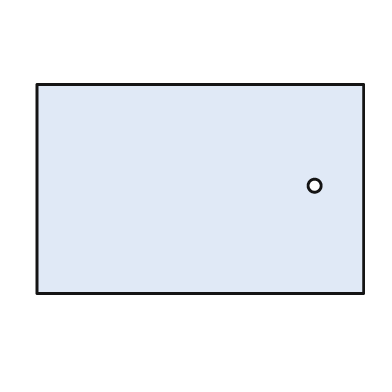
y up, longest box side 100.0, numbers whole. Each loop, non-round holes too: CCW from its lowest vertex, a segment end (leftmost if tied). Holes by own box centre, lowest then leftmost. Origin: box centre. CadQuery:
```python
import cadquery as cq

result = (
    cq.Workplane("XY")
    .moveTo(-50.0, -32.0)
    .lineTo(50.0, -32.0)
    .lineTo(50.0, 32.0)
    .lineTo(-50.0, 32.0)
    .close()
    .moveTo(35.0, 1.0)
    .circle(2.0)
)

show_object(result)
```